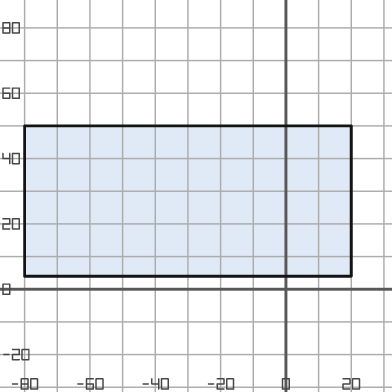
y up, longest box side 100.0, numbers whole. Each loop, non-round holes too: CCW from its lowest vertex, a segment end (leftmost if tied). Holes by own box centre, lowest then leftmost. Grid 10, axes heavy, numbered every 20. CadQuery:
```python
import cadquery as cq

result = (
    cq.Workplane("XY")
    .moveTo(-80.0, 4.0)
    .lineTo(20.0, 4.0)
    .lineTo(20.0, 50.0)
    .lineTo(-80.0, 50.0)
    .close()
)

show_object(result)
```